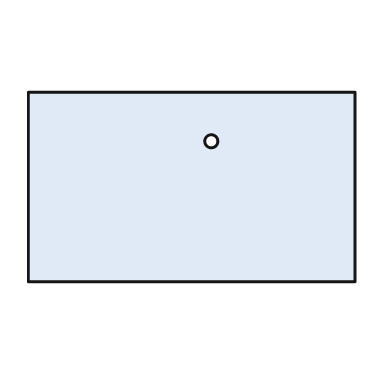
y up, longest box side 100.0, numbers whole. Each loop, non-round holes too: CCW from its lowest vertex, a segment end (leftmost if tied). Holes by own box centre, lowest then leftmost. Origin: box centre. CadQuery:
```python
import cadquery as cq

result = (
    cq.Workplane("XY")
    .moveTo(-50.0, -29.0)
    .lineTo(50.0, -29.0)
    .lineTo(50.0, 29.0)
    .lineTo(-50.0, 29.0)
    .close()
    .moveTo(6.0, 14.0)
    .circle(2.0)
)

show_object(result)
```